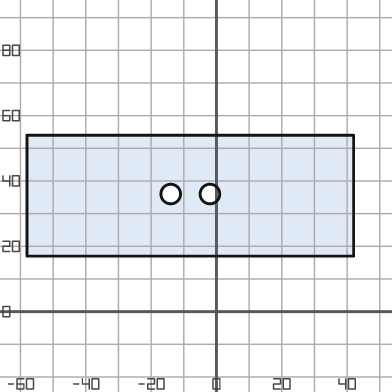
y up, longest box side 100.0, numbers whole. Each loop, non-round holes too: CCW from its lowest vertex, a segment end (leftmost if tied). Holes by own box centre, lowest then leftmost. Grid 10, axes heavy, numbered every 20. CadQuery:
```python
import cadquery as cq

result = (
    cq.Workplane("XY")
    .moveTo(-58.0, 17.0)
    .lineTo(42.0, 17.0)
    .lineTo(42.0, 54.0)
    .lineTo(-58.0, 54.0)
    .close()
    .moveTo(-14.0, 36.0)
    .circle(3.0)
    .moveTo(-2.0, 36.0)
    .circle(3.0)
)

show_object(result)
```